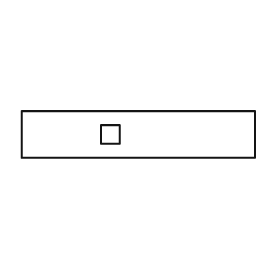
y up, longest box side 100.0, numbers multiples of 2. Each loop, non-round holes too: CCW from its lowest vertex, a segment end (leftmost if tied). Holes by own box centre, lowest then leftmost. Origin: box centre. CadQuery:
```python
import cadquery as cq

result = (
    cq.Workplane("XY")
    .moveTo(-50.0, -10.0)
    .lineTo(50.0, -10.0)
    .lineTo(50.0, 10.0)
    .lineTo(-50.0, 10.0)
    .close()
    .moveTo(-16.0, -4.0)
    .lineTo(-8.0, -4.0)
    .lineTo(-8.0, 4.0)
    .lineTo(-16.0, 4.0)
    .close()
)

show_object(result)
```